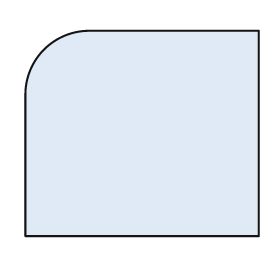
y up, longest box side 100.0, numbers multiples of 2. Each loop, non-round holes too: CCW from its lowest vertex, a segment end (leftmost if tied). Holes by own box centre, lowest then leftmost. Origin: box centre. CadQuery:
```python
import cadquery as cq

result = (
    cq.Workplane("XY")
    .moveTo(-50.0, -44.0)
    .lineTo(50.0, -44.0)
    .lineTo(50.0, 44.0)
    .lineTo(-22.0, 44.0)
    .threePointArc((-42.0, 36.0), (-50.0, 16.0))
    .close()
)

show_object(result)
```